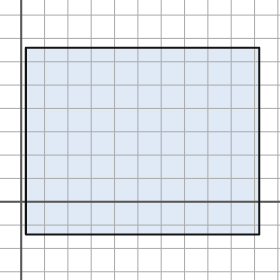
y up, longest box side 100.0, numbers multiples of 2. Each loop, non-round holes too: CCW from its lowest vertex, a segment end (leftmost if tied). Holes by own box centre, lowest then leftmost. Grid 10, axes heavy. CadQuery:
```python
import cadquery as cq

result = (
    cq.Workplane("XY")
    .moveTo(2.0, -14.0)
    .lineTo(102.0, -14.0)
    .lineTo(102.0, 66.0)
    .lineTo(2.0, 66.0)
    .close()
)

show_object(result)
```